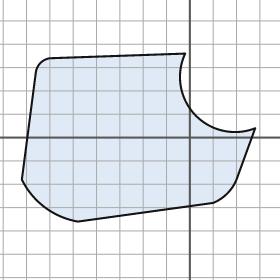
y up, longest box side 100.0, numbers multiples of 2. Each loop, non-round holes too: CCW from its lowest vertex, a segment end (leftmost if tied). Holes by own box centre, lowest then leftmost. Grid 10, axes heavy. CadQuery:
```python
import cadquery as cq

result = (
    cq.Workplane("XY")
    .moveTo(-48.0, -36.0)
    .lineTo(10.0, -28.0)
    .threePointArc((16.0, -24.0), (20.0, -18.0))
    .lineTo(28.0, 4.0)
    .threePointArc((2.0, 10.0), (-2.0, 36.0))
    .lineTo(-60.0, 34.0)
    .threePointArc((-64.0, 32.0), (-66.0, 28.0))
    .lineTo(-72.0, -18.0)
    .threePointArc((-62.0, -30.0), (-48.0, -36.0))
    .close()
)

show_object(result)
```